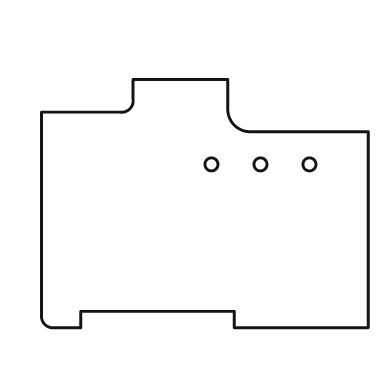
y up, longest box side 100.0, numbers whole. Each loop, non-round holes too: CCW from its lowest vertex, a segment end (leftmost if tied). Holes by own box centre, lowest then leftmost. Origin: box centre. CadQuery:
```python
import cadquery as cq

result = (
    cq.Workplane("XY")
    .moveTo(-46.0, -38.0)
    .lineTo(-38.0, -38.0)
    .lineTo(-38.0, -33.0)
    .lineTo(9.0, -33.0)
    .lineTo(9.0, -38.0)
    .lineTo(50.0, -38.0)
    .lineTo(50.0, 22.0)
    .lineTo(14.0, 22.0)
    .threePointArc((9.0, 24.0), (7.0, 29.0))
    .lineTo(7.0, 38.0)
    .lineTo(-22.0, 38.0)
    .lineTo(-22.0, 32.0)
    .threePointArc((-23.0, 29.0), (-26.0, 28.0))
    .lineTo(-50.0, 28.0)
    .lineTo(-50.0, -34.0)
    .threePointArc((-49.0, -37.0), (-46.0, -38.0))
    .close()
    .moveTo(2.0, 12.0)
    .circle(2.0)
    .moveTo(17.0, 12.0)
    .circle(2.0)
    .moveTo(32.0, 12.0)
    .circle(2.0)
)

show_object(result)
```